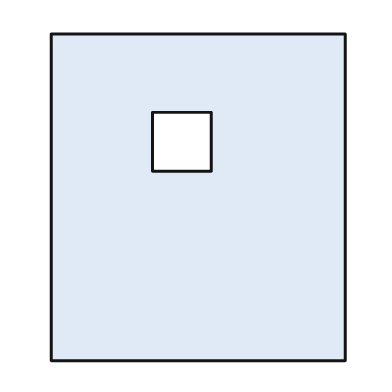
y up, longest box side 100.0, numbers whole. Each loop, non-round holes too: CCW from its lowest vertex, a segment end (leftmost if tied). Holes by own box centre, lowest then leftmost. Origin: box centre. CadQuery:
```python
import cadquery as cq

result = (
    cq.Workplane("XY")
    .moveTo(-45.0, -50.0)
    .lineTo(45.0, -50.0)
    .lineTo(45.0, 50.0)
    .lineTo(-45.0, 50.0)
    .close()
    .moveTo(-14.0, 8.0)
    .lineTo(4.0, 8.0)
    .lineTo(4.0, 26.0)
    .lineTo(-14.0, 26.0)
    .close()
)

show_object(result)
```